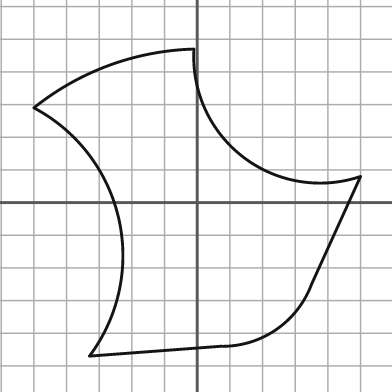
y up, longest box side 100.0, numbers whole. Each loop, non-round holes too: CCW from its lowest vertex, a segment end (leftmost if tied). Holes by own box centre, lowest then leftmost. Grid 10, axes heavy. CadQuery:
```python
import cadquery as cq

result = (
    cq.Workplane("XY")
    .moveTo(-33.0, -47.0)
    .lineTo(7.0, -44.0)
    .threePointArc((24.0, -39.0), (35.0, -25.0))
    .lineTo(50.0, 8.0)
    .threePointArc((14.0, 14.0), (-1.0, 47.0))
    .threePointArc((-27.0, 42.0), (-50.0, 29.0))
    .threePointArc((-24.0, -5.0), (-33.0, -47.0))
    .close()
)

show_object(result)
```